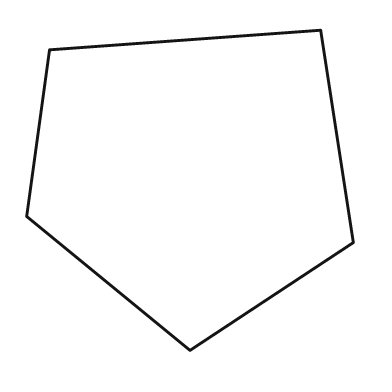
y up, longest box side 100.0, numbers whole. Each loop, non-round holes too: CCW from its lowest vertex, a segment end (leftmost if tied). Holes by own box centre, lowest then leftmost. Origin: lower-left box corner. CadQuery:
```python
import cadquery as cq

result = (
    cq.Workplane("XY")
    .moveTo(50.0, 0.0)
    .lineTo(100.0, 33.0)
    .lineTo(90.0, 98.0)
    .lineTo(7.0, 92.0)
    .lineTo(0.0, 41.0)
    .close()
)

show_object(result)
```